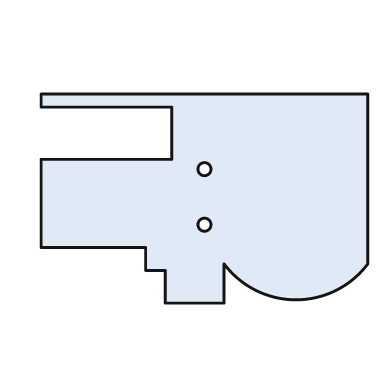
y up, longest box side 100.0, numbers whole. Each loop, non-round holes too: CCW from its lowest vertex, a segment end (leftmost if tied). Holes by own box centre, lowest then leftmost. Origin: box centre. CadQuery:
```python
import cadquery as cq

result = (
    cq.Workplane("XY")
    .moveTo(-12.0, -32.0)
    .lineTo(6.0, -32.0)
    .lineTo(6.0, -20.0)
    .threePointArc((28.0, -31.0), (50.0, -20.0))
    .lineTo(50.0, 32.0)
    .lineTo(-50.0, 32.0)
    .lineTo(-50.0, 28.0)
    .lineTo(-10.0, 28.0)
    .lineTo(-10.0, 12.0)
    .lineTo(-50.0, 12.0)
    .lineTo(-50.0, -15.0)
    .lineTo(-18.0, -15.0)
    .lineTo(-18.0, -22.0)
    .lineTo(-12.0, -22.0)
    .close()
    .moveTo(0.0, -8.0)
    .circle(2.0)
    .moveTo(0.0, 9.0)
    .circle(2.0)
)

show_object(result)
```